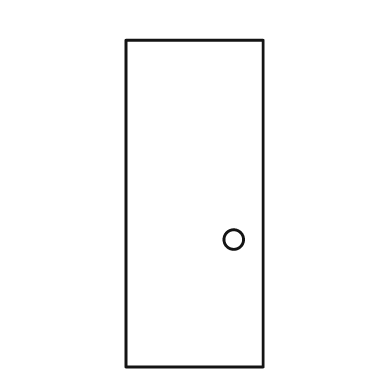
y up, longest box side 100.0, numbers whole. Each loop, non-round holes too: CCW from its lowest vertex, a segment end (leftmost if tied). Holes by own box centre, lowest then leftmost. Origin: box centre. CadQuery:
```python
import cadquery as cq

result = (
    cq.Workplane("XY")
    .moveTo(-21.0, -50.0)
    .lineTo(21.0, -50.0)
    .lineTo(21.0, 50.0)
    .lineTo(-21.0, 50.0)
    .close()
    .moveTo(12.0, -11.0)
    .circle(3.0)
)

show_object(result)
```